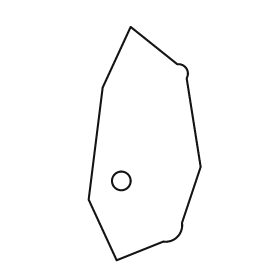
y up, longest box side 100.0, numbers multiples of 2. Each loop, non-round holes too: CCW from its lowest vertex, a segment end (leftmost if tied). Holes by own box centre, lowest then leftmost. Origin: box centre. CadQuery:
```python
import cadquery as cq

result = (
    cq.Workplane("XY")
    .moveTo(-12.0, -50.0)
    .lineTo(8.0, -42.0)
    .threePointArc((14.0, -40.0), (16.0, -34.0))
    .lineTo(24.0, -10.0)
    .lineTo(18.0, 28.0)
    .threePointArc((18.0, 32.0), (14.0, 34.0))
    .lineTo(-6.0, 50.0)
    .lineTo(-18.0, 24.0)
    .lineTo(-24.0, -24.0)
    .close()
    .moveTo(-10.0, -16.0)
    .circle(4.0)
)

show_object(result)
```